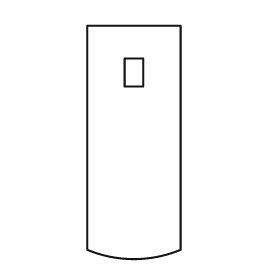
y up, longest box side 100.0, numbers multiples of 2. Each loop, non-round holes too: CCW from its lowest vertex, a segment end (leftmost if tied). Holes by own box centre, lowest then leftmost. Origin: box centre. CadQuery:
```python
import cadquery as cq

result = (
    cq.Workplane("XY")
    .moveTo(-20.0, -46.0)
    .threePointArc((0.0, -50.0), (20.0, -46.0))
    .lineTo(20.0, 50.0)
    .lineTo(-20.0, 50.0)
    .close()
    .moveTo(-4.0, 24.0)
    .lineTo(4.0, 24.0)
    .lineTo(4.0, 36.0)
    .lineTo(-4.0, 36.0)
    .close()
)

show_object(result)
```